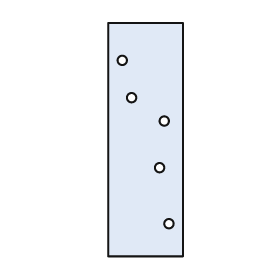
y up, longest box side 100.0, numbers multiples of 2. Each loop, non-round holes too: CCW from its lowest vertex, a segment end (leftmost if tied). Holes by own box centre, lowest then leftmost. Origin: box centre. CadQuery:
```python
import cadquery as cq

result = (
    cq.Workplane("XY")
    .moveTo(-16.0, -50.0)
    .lineTo(16.0, -50.0)
    .lineTo(16.0, 50.0)
    .lineTo(-16.0, 50.0)
    .close()
    .moveTo(10.0, -36.0)
    .circle(2.0)
    .moveTo(6.0, -12.0)
    .circle(2.0)
    .moveTo(8.0, 8.0)
    .circle(2.0)
    .moveTo(-6.0, 18.0)
    .circle(2.0)
    .moveTo(-10.0, 34.0)
    .circle(2.0)
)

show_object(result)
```